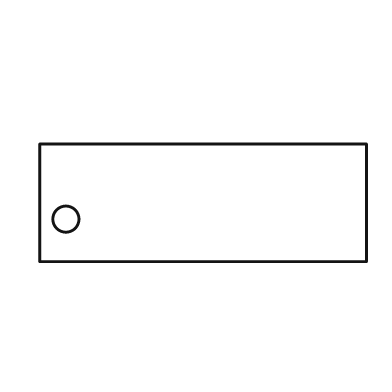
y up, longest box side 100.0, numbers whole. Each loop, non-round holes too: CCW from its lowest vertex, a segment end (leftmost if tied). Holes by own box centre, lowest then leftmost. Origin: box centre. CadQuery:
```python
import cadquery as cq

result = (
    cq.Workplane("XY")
    .moveTo(-50.0, -18.0)
    .lineTo(50.0, -18.0)
    .lineTo(50.0, 18.0)
    .lineTo(-50.0, 18.0)
    .close()
    .moveTo(-42.0, -5.0)
    .circle(4.0)
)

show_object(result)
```